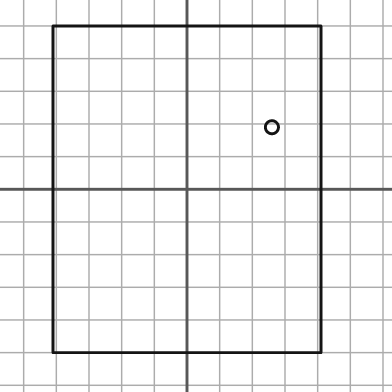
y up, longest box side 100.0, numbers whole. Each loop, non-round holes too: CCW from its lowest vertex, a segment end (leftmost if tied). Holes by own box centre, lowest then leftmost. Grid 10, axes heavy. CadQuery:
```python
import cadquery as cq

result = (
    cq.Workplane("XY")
    .moveTo(-41.0, -50.0)
    .lineTo(41.0, -50.0)
    .lineTo(41.0, 50.0)
    .lineTo(-41.0, 50.0)
    .close()
    .moveTo(26.0, 19.0)
    .circle(2.0)
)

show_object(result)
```